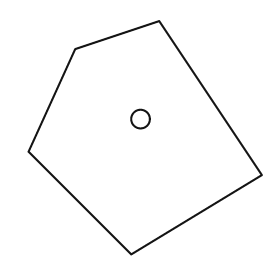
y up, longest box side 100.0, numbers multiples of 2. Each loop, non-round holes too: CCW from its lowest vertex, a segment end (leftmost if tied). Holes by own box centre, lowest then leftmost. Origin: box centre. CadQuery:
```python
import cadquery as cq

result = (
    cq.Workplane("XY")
    .moveTo(-6.0, -50.0)
    .lineTo(50.0, -16.0)
    .lineTo(6.0, 50.0)
    .lineTo(-30.0, 38.0)
    .lineTo(-50.0, -6.0)
    .close()
    .moveTo(-2.0, 8.0)
    .circle(4.0)
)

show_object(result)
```